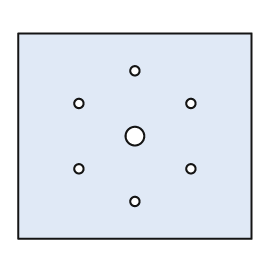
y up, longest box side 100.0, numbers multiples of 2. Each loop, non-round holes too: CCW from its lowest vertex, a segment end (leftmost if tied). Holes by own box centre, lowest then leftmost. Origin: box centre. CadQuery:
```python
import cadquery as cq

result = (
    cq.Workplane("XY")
    .moveTo(-50.0, -44.0)
    .lineTo(50.0, -44.0)
    .lineTo(50.0, 44.0)
    .lineTo(-50.0, 44.0)
    .close()
    .moveTo(0.0, -28.0)
    .circle(2.0)
    .moveTo(-24.0, -14.0)
    .circle(2.0)
    .moveTo(24.0, -14.0)
    .circle(2.0)
    .moveTo(0.0, 0.0)
    .circle(4.0)
    .moveTo(-24.0, 14.0)
    .circle(2.0)
    .moveTo(24.0, 14.0)
    .circle(2.0)
    .moveTo(0.0, 28.0)
    .circle(2.0)
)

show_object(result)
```